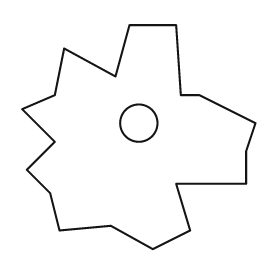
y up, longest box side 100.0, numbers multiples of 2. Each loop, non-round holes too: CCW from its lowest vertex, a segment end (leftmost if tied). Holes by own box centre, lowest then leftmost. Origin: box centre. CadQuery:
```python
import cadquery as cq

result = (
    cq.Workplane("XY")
    .moveTo(6.0, -48.0)
    .lineTo(22.0, -40.0)
    .lineTo(16.0, -20.0)
    .lineTo(46.0, -20.0)
    .lineTo(46.0, -6.0)
    .lineTo(50.0, 6.0)
    .lineTo(26.0, 18.0)
    .lineTo(18.0, 18.0)
    .lineTo(16.0, 48.0)
    .lineTo(-4.0, 48.0)
    .lineTo(-10.0, 26.0)
    .lineTo(-32.0, 38.0)
    .lineTo(-36.0, 18.0)
    .lineTo(-50.0, 12.0)
    .lineTo(-36.0, -2.0)
    .lineTo(-48.0, -14.0)
    .lineTo(-38.0, -24.0)
    .lineTo(-34.0, -40.0)
    .lineTo(-12.0, -38.0)
    .close()
    .moveTo(0.0, 6.0)
    .circle(8.0)
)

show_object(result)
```